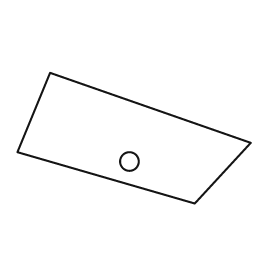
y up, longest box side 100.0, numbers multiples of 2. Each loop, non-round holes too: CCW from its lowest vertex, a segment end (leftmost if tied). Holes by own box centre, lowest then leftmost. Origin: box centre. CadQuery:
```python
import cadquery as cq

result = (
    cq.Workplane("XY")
    .moveTo(26.0, -28.0)
    .lineTo(50.0, -2.0)
    .lineTo(-36.0, 28.0)
    .lineTo(-50.0, -6.0)
    .close()
    .moveTo(-2.0, -10.0)
    .circle(4.0)
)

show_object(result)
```